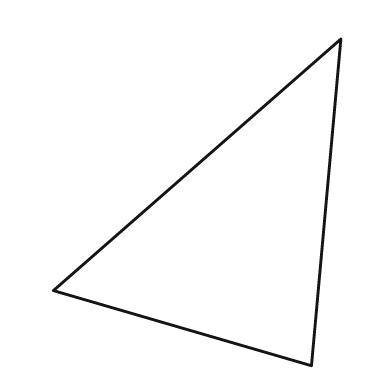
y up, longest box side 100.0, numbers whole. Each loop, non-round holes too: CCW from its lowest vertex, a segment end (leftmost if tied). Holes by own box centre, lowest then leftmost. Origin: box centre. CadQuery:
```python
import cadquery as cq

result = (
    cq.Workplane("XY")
    .moveTo(35.0, -50.0)
    .lineTo(44.0, 50.0)
    .lineTo(-44.0, -27.0)
    .close()
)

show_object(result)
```